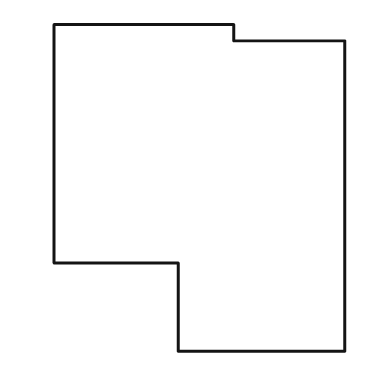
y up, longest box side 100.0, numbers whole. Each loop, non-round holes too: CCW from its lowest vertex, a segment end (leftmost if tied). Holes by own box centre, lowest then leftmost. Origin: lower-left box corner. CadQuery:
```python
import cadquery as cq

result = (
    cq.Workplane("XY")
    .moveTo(38.0, 0.0)
    .lineTo(89.0, 0.0)
    .lineTo(89.0, 95.0)
    .lineTo(55.0, 95.0)
    .lineTo(55.0, 100.0)
    .lineTo(0.0, 100.0)
    .lineTo(0.0, 27.0)
    .lineTo(38.0, 27.0)
    .close()
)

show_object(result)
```